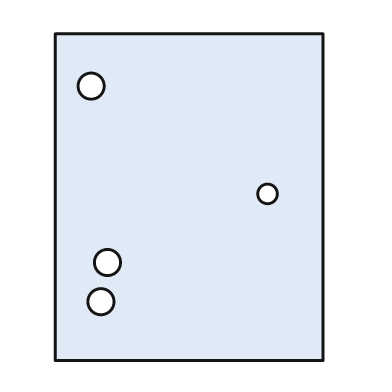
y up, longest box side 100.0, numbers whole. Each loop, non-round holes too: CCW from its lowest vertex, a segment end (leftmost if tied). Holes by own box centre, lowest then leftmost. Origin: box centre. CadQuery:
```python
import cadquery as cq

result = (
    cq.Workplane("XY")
    .moveTo(-41.0, -50.0)
    .lineTo(41.0, -50.0)
    .lineTo(41.0, 50.0)
    .lineTo(-41.0, 50.0)
    .close()
    .moveTo(-27.0, -32.0)
    .circle(4.0)
    .moveTo(-25.0, -20.0)
    .circle(4.0)
    .moveTo(24.0, 1.0)
    .circle(3.0)
    .moveTo(-30.0, 34.0)
    .circle(4.0)
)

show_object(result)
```